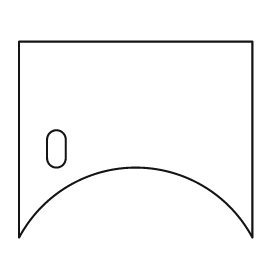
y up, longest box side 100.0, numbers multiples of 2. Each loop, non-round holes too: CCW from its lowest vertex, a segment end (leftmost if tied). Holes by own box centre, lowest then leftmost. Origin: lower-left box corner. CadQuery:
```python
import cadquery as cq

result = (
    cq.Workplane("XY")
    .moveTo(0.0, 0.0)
    .threePointArc((50.0, 30.0), (100.0, 0.0))
    .lineTo(100.0, 84.0)
    .lineTo(0.0, 84.0)
    .close()
    .moveTo(12.0, 34.0)
    .threePointArc((16.0, 30.0), (20.0, 34.0))
    .lineTo(20.0, 42.0)
    .threePointArc((16.0, 46.0), (12.0, 42.0))
    .close()
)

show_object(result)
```